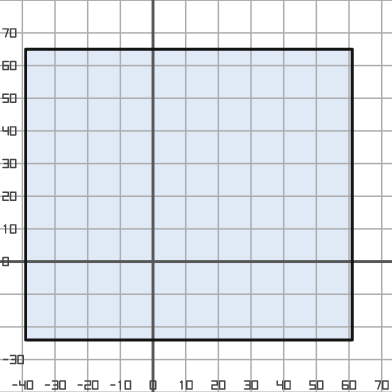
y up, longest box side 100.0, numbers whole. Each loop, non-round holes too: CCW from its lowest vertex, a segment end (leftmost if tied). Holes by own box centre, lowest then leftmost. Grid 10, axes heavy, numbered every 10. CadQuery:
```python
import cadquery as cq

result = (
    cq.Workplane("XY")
    .moveTo(-39.0, -24.0)
    .lineTo(61.0, -24.0)
    .lineTo(61.0, 65.0)
    .lineTo(-39.0, 65.0)
    .close()
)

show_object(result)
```